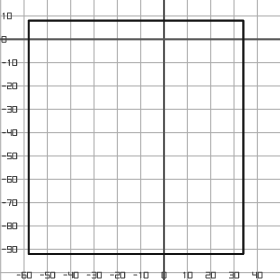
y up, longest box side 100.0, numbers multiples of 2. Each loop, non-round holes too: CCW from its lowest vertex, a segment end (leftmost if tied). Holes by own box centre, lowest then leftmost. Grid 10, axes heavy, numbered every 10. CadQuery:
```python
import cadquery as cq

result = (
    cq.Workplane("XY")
    .moveTo(-58.0, -92.0)
    .lineTo(34.0, -92.0)
    .lineTo(34.0, 8.0)
    .lineTo(-58.0, 8.0)
    .close()
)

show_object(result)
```